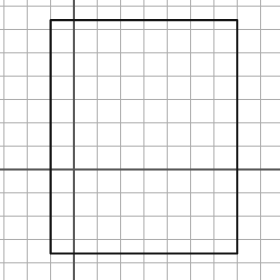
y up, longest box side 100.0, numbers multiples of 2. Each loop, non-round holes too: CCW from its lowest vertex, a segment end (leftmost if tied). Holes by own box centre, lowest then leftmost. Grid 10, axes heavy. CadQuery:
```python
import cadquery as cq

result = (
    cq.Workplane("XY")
    .moveTo(-10.0, -36.0)
    .lineTo(70.0, -36.0)
    .lineTo(70.0, 64.0)
    .lineTo(-10.0, 64.0)
    .close()
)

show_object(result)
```